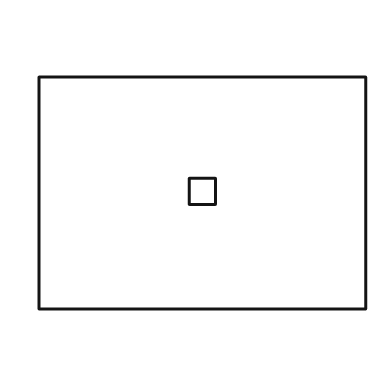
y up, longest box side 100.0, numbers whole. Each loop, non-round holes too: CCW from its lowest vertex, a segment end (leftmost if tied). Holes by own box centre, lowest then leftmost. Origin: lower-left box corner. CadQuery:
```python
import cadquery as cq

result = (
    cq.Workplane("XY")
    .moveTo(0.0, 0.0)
    .lineTo(100.0, 0.0)
    .lineTo(100.0, 71.0)
    .lineTo(0.0, 71.0)
    .close()
    .moveTo(46.0, 32.0)
    .lineTo(54.0, 32.0)
    .lineTo(54.0, 40.0)
    .lineTo(46.0, 40.0)
    .close()
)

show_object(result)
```